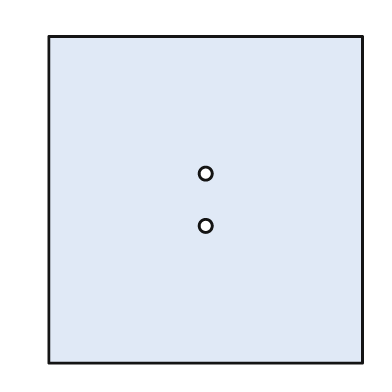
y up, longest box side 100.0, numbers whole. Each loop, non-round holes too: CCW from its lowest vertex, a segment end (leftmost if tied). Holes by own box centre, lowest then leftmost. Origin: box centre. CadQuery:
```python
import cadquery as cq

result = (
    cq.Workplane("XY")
    .moveTo(-48.0, -50.0)
    .lineTo(48.0, -50.0)
    .lineTo(48.0, 50.0)
    .lineTo(-48.0, 50.0)
    .close()
    .moveTo(0.0, -8.0)
    .circle(2.0)
    .moveTo(0.0, 8.0)
    .circle(2.0)
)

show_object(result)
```